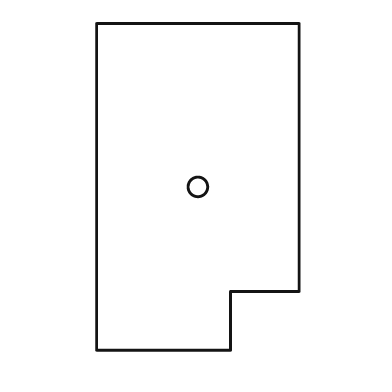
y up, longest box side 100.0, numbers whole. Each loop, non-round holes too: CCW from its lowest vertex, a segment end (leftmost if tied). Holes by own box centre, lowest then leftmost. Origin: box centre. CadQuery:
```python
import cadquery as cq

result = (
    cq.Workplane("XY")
    .moveTo(-31.0, -50.0)
    .lineTo(10.0, -50.0)
    .lineTo(10.0, -32.0)
    .lineTo(31.0, -32.0)
    .lineTo(31.0, 50.0)
    .lineTo(-31.0, 50.0)
    .close()
    .moveTo(0.0, 0.0)
    .circle(3.0)
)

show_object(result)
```